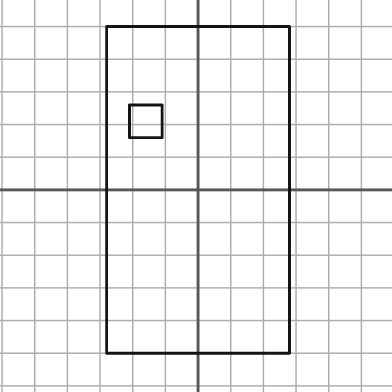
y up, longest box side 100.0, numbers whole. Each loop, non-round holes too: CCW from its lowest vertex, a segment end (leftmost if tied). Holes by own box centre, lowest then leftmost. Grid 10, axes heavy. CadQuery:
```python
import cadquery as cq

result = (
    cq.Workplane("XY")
    .moveTo(-28.0, -50.0)
    .lineTo(28.0, -50.0)
    .lineTo(28.0, 50.0)
    .lineTo(-28.0, 50.0)
    .close()
    .moveTo(-21.0, 16.0)
    .lineTo(-11.0, 16.0)
    .lineTo(-11.0, 26.0)
    .lineTo(-21.0, 26.0)
    .close()
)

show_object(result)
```